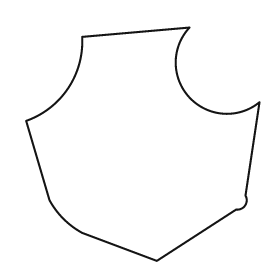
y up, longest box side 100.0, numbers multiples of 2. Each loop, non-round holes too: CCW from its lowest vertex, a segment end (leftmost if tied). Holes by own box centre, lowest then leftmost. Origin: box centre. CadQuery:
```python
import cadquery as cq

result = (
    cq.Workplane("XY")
    .moveTo(6.0, -50.0)
    .lineTo(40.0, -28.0)
    .threePointArc((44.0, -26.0), (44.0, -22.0))
    .lineTo(50.0, 18.0)
    .threePointArc((20.0, 20.0), (20.0, 50.0))
    .lineTo(-26.0, 46.0)
    .threePointArc((-32.0, 24.0), (-50.0, 10.0))
    .lineTo(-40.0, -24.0)
    .threePointArc((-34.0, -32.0), (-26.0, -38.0))
    .close()
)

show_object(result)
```